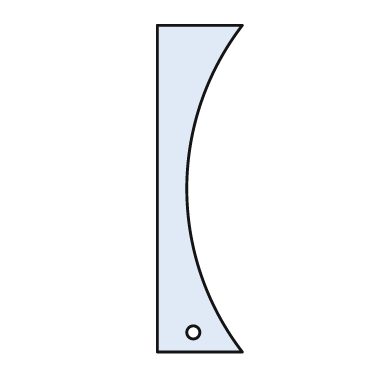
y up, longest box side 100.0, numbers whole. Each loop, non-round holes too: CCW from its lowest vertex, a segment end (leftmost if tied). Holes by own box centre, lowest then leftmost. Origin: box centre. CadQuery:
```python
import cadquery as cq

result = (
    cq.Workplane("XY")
    .moveTo(-13.0, -50.0)
    .lineTo(13.0, -50.0)
    .threePointArc((-4.0, 0.0), (13.0, 50.0))
    .lineTo(-13.0, 50.0)
    .close()
    .moveTo(-2.0, -44.0)
    .circle(2.0)
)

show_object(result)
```